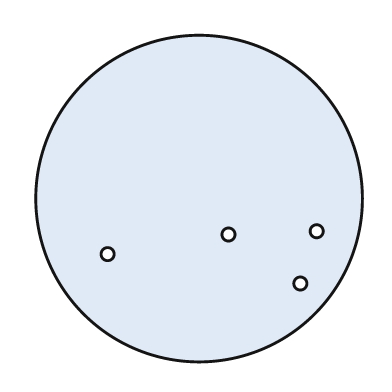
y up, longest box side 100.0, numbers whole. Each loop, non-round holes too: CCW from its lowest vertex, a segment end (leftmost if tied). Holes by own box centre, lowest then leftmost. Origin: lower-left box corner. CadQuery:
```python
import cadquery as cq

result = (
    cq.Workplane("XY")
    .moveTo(50.0, 50.0)
    .circle(50.0)
    .moveTo(81.0, 24.0)
    .circle(2.0)
    .moveTo(22.0, 33.0)
    .circle(2.0)
    .moveTo(59.0, 39.0)
    .circle(2.0)
    .moveTo(86.0, 40.0)
    .circle(2.0)
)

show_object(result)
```